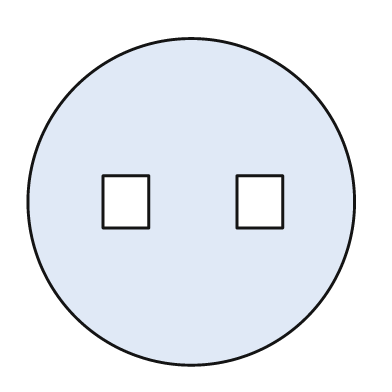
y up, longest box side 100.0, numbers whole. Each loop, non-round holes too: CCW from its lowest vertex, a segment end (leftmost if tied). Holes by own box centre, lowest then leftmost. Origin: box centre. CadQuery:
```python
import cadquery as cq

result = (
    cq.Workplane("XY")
    .moveTo(0.0, 0.0)
    .circle(50.0)
    .moveTo(-27.0, -8.0)
    .lineTo(-13.0, -8.0)
    .lineTo(-13.0, 8.0)
    .lineTo(-27.0, 8.0)
    .close()
    .moveTo(14.0, -8.0)
    .lineTo(28.0, -8.0)
    .lineTo(28.0, 8.0)
    .lineTo(14.0, 8.0)
    .close()
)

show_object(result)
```